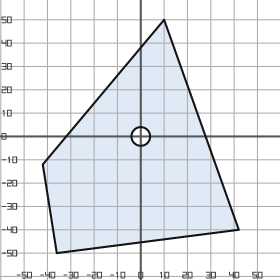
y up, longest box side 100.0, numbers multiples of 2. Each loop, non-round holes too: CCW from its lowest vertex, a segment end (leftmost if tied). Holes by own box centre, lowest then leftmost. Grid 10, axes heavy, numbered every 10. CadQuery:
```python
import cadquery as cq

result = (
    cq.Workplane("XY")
    .moveTo(-36.0, -50.0)
    .lineTo(42.0, -40.0)
    .lineTo(10.0, 50.0)
    .lineTo(-42.0, -12.0)
    .close()
    .moveTo(0.0, 0.0)
    .circle(4.0)
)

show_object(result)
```